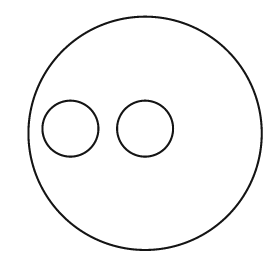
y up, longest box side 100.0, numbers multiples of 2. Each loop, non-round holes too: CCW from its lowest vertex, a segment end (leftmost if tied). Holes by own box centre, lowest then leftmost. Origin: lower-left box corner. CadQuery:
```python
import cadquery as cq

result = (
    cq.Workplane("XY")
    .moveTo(50.0, 50.0)
    .circle(50.0)
    .moveTo(18.0, 52.0)
    .circle(12.0)
    .moveTo(50.0, 52.0)
    .circle(12.0)
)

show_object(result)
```